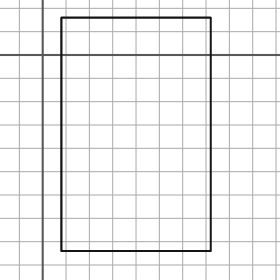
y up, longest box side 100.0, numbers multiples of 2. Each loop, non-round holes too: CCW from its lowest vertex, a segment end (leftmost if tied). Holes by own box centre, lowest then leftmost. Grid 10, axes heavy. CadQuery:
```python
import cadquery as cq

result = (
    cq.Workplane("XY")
    .moveTo(8.0, -84.0)
    .lineTo(72.0, -84.0)
    .lineTo(72.0, 16.0)
    .lineTo(8.0, 16.0)
    .close()
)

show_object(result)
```